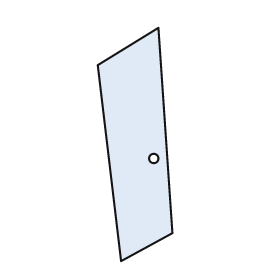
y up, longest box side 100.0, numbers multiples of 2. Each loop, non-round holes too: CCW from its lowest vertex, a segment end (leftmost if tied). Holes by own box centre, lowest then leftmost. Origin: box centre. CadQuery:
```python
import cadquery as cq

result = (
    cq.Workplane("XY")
    .moveTo(-6.0, -50.0)
    .lineTo(16.0, -38.0)
    .lineTo(10.0, 50.0)
    .lineTo(-16.0, 34.0)
    .close()
    .moveTo(8.0, -6.0)
    .circle(2.0)
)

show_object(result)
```